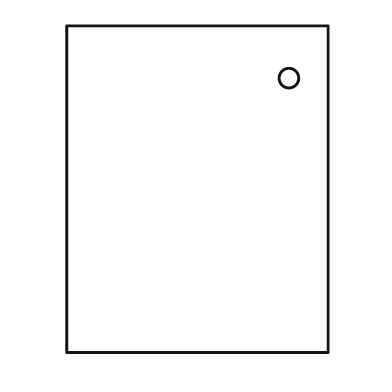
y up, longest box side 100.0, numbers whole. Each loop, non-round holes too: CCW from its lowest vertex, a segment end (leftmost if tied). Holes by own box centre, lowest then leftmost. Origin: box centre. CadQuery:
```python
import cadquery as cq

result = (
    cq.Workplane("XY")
    .moveTo(-40.0, -50.0)
    .lineTo(40.0, -50.0)
    .lineTo(40.0, 50.0)
    .lineTo(-40.0, 50.0)
    .close()
    .moveTo(28.0, 34.0)
    .circle(3.0)
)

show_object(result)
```